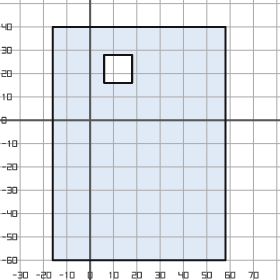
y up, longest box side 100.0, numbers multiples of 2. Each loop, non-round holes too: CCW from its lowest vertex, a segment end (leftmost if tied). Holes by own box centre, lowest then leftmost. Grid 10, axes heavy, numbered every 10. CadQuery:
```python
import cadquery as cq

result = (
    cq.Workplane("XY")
    .moveTo(-16.0, -60.0)
    .lineTo(58.0, -60.0)
    .lineTo(58.0, 40.0)
    .lineTo(-16.0, 40.0)
    .close()
    .moveTo(6.0, 16.0)
    .lineTo(18.0, 16.0)
    .lineTo(18.0, 28.0)
    .lineTo(6.0, 28.0)
    .close()
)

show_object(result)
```